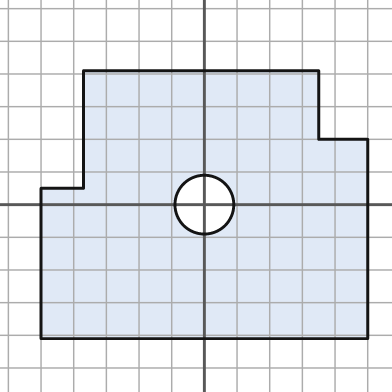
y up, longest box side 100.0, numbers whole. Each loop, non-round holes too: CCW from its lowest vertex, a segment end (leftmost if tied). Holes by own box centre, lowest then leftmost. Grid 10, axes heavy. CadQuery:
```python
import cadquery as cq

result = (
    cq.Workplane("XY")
    .moveTo(-50.0, -41.0)
    .lineTo(50.0, -41.0)
    .lineTo(50.0, 20.0)
    .lineTo(35.0, 20.0)
    .lineTo(35.0, 41.0)
    .lineTo(-37.0, 41.0)
    .lineTo(-37.0, 5.0)
    .lineTo(-50.0, 5.0)
    .close()
    .moveTo(0.0, 0.0)
    .circle(9.0)
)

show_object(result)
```